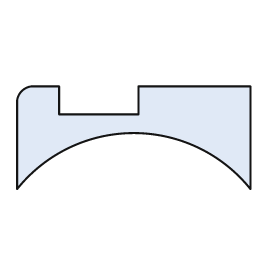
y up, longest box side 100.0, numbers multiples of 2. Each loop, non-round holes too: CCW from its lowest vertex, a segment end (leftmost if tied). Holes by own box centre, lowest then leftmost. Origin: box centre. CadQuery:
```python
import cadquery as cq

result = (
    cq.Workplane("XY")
    .moveTo(-50.0, -22.0)
    .threePointArc((0.0, 2.0), (50.0, -22.0))
    .lineTo(50.0, 22.0)
    .lineTo(2.0, 22.0)
    .lineTo(2.0, 10.0)
    .lineTo(-32.0, 10.0)
    .lineTo(-32.0, 22.0)
    .lineTo(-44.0, 22.0)
    .threePointArc((-48.0, 20.0), (-50.0, 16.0))
    .close()
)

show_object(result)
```